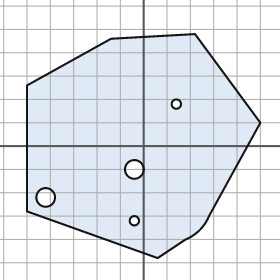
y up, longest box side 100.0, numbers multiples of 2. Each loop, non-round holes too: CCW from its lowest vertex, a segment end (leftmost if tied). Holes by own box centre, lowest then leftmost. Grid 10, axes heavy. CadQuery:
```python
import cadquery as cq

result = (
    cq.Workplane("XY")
    .moveTo(6.0, -48.0)
    .lineTo(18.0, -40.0)
    .threePointArc((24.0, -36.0), (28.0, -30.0))
    .lineTo(50.0, 10.0)
    .lineTo(22.0, 48.0)
    .lineTo(-14.0, 46.0)
    .lineTo(-50.0, 26.0)
    .lineTo(-50.0, -28.0)
    .close()
    .moveTo(-4.0, -32.0)
    .circle(2.0)
    .moveTo(-42.0, -22.0)
    .circle(4.0)
    .moveTo(-4.0, -10.0)
    .circle(4.0)
    .moveTo(14.0, 18.0)
    .circle(2.0)
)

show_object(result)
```